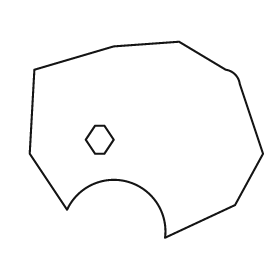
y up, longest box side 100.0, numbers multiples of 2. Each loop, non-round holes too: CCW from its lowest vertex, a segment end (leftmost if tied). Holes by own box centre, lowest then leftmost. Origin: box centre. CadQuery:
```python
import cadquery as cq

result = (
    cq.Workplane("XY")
    .moveTo(8.0, -42.0)
    .lineTo(38.0, -28.0)
    .lineTo(50.0, -6.0)
    .lineTo(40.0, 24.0)
    .threePointArc((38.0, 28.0), (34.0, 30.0))
    .lineTo(14.0, 42.0)
    .lineTo(-14.0, 40.0)
    .lineTo(-48.0, 30.0)
    .lineTo(-50.0, -6.0)
    .lineTo(-34.0, -30.0)
    .threePointArc((-8.0, -18.0), (8.0, -42.0))
    .close()
    .moveTo(-22.0, -6.0)
    .lineTo(-18.0, -6.0)
    .lineTo(-14.0, 0.0)
    .lineTo(-18.0, 6.0)
    .lineTo(-22.0, 6.0)
    .lineTo(-26.0, 0.0)
    .close()
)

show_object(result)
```